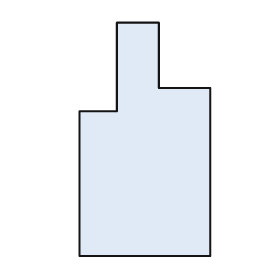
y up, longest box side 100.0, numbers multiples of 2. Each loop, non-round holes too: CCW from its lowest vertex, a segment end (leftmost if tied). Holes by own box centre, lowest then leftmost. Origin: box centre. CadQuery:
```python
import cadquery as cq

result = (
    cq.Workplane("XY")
    .moveTo(-28.0, -50.0)
    .lineTo(28.0, -50.0)
    .lineTo(28.0, 22.0)
    .lineTo(6.0, 22.0)
    .lineTo(6.0, 50.0)
    .lineTo(-12.0, 50.0)
    .lineTo(-12.0, 12.0)
    .lineTo(-28.0, 12.0)
    .close()
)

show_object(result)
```